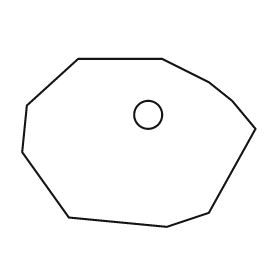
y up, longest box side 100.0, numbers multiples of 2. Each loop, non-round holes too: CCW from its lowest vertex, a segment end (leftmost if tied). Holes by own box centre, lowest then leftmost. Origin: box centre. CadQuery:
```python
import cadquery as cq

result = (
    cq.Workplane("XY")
    .moveTo(12.0, -36.0)
    .lineTo(30.0, -30.0)
    .lineTo(50.0, 6.0)
    .lineTo(40.0, 18.0)
    .lineTo(30.0, 26.0)
    .lineTo(10.0, 36.0)
    .lineTo(-26.0, 36.0)
    .lineTo(-48.0, 16.0)
    .lineTo(-50.0, -4.0)
    .lineTo(-30.0, -32.0)
    .close()
    .moveTo(4.0, 12.0)
    .circle(6.0)
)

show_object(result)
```